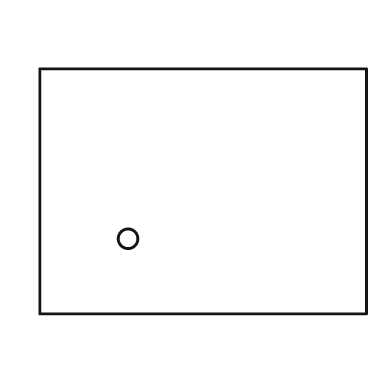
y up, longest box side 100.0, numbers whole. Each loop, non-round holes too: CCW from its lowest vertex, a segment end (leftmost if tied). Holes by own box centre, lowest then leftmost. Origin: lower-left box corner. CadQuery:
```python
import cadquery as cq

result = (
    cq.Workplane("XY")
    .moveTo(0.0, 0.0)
    .lineTo(100.0, 0.0)
    .lineTo(100.0, 75.0)
    .lineTo(0.0, 75.0)
    .close()
    .moveTo(27.0, 23.0)
    .circle(3.0)
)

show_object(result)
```